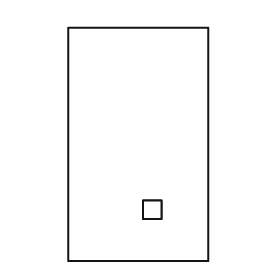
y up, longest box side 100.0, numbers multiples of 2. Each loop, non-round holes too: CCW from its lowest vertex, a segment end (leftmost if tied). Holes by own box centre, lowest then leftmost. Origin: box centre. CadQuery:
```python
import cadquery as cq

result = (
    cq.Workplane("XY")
    .moveTo(-30.0, -50.0)
    .lineTo(30.0, -50.0)
    .lineTo(30.0, 50.0)
    .lineTo(-30.0, 50.0)
    .close()
    .moveTo(2.0, -32.0)
    .lineTo(10.0, -32.0)
    .lineTo(10.0, -24.0)
    .lineTo(2.0, -24.0)
    .close()
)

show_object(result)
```